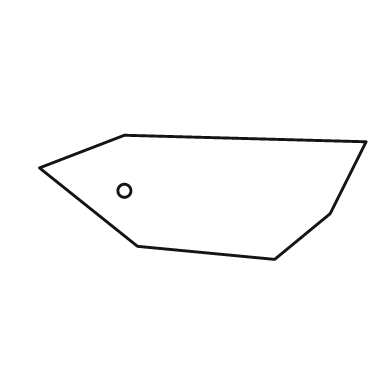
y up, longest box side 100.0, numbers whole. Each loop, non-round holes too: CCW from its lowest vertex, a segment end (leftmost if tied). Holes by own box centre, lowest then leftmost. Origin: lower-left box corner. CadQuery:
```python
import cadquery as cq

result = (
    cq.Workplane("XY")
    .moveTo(72.0, 0.0)
    .lineTo(89.0, 14.0)
    .lineTo(100.0, 36.0)
    .lineTo(26.0, 38.0)
    .lineTo(0.0, 28.0)
    .lineTo(30.0, 4.0)
    .close()
    .moveTo(26.0, 21.0)
    .circle(2.0)
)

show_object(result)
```